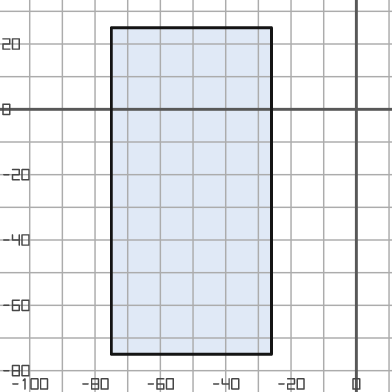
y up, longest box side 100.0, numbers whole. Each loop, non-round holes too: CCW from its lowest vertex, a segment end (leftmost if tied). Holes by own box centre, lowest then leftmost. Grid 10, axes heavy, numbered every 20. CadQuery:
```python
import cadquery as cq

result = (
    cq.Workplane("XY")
    .moveTo(-75.0, -75.0)
    .lineTo(-26.0, -75.0)
    .lineTo(-26.0, 25.0)
    .lineTo(-75.0, 25.0)
    .close()
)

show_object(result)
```